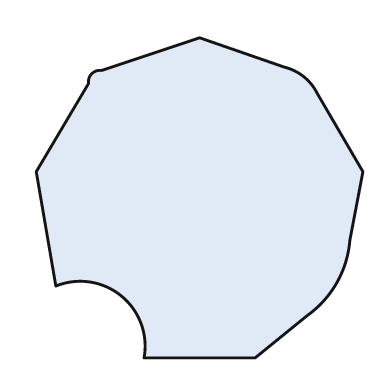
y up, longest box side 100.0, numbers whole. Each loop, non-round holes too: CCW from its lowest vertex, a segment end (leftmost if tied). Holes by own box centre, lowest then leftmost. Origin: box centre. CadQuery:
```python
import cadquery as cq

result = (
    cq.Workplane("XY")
    .moveTo(-17.0, -49.0)
    .lineTo(17.0, -49.0)
    .lineTo(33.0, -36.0)
    .threePointArc((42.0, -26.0), (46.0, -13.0))
    .lineTo(50.0, 8.0)
    .lineTo(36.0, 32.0)
    .threePointArc((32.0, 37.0), (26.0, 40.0))
    .lineTo(0.0, 49.0)
    .lineTo(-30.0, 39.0)
    .threePointArc((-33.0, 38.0), (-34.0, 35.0))
    .lineTo(-50.0, 8.0)
    .lineTo(-44.0, -27.0)
    .threePointArc((-24.0, -30.0), (-17.0, -49.0))
    .close()
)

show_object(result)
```